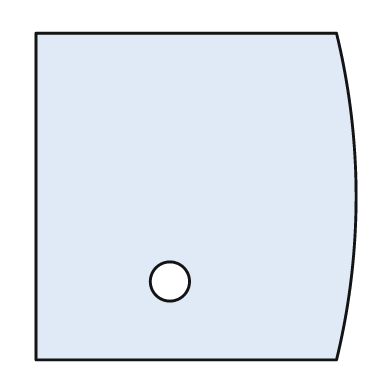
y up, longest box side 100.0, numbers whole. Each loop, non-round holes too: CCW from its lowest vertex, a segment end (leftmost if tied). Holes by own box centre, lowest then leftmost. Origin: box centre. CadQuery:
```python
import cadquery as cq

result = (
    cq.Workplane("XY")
    .moveTo(-49.0, -50.0)
    .lineTo(43.0, -50.0)
    .threePointArc((49.0, 0.0), (43.0, 50.0))
    .lineTo(-49.0, 50.0)
    .close()
    .moveTo(-8.0, -26.0)
    .circle(6.0)
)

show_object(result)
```